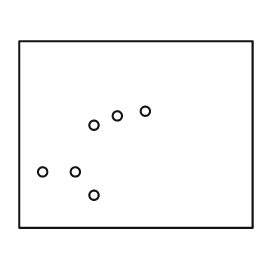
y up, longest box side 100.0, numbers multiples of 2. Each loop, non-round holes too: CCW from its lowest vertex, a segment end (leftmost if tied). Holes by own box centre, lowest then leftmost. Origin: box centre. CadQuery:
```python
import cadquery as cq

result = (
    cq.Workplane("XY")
    .moveTo(-50.0, -40.0)
    .lineTo(50.0, -40.0)
    .lineTo(50.0, 40.0)
    .lineTo(-50.0, 40.0)
    .close()
    .moveTo(-18.0, -26.0)
    .circle(2.0)
    .moveTo(-40.0, -16.0)
    .circle(2.0)
    .moveTo(-26.0, -16.0)
    .circle(2.0)
    .moveTo(-18.0, 4.0)
    .circle(2.0)
    .moveTo(-8.0, 8.0)
    .circle(2.0)
    .moveTo(4.0, 10.0)
    .circle(2.0)
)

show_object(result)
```